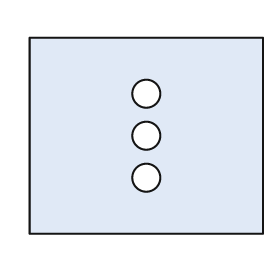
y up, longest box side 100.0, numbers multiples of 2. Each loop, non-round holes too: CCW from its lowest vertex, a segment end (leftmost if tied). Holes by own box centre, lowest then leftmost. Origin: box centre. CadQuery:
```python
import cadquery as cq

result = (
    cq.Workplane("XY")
    .moveTo(-50.0, -42.0)
    .lineTo(50.0, -42.0)
    .lineTo(50.0, 42.0)
    .lineTo(-50.0, 42.0)
    .close()
    .moveTo(0.0, -18.0)
    .circle(6.0)
    .moveTo(0.0, 0.0)
    .circle(6.0)
    .moveTo(0.0, 18.0)
    .circle(6.0)
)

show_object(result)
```